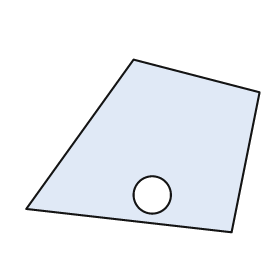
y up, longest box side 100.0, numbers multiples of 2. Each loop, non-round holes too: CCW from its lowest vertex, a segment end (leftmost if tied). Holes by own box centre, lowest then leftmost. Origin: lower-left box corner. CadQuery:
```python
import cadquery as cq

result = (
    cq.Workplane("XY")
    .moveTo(88.0, 0.0)
    .lineTo(100.0, 60.0)
    .lineTo(46.0, 74.0)
    .lineTo(0.0, 10.0)
    .close()
    .moveTo(54.0, 16.0)
    .circle(8.0)
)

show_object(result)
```